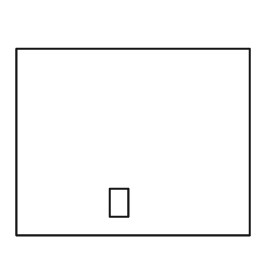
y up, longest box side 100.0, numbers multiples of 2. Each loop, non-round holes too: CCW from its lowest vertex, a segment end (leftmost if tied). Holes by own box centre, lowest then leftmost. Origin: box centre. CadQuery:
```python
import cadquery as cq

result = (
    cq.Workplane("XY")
    .moveTo(-50.0, -40.0)
    .lineTo(50.0, -40.0)
    .lineTo(50.0, 40.0)
    .lineTo(-50.0, 40.0)
    .close()
    .moveTo(-10.0, -32.0)
    .lineTo(-2.0, -32.0)
    .lineTo(-2.0, -20.0)
    .lineTo(-10.0, -20.0)
    .close()
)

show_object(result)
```